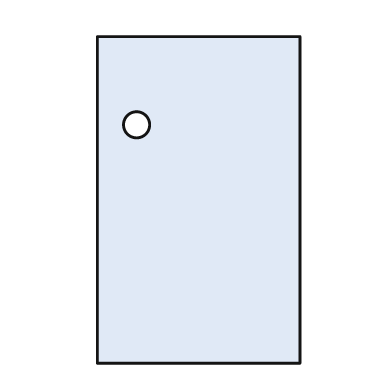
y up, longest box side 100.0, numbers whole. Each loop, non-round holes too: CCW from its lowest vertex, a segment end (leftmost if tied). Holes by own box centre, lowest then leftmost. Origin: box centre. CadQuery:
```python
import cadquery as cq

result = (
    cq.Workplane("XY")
    .moveTo(-31.0, -50.0)
    .lineTo(31.0, -50.0)
    .lineTo(31.0, 50.0)
    .lineTo(-31.0, 50.0)
    .close()
    .moveTo(-19.0, 23.0)
    .circle(4.0)
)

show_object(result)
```